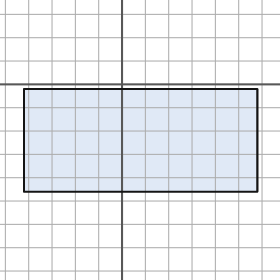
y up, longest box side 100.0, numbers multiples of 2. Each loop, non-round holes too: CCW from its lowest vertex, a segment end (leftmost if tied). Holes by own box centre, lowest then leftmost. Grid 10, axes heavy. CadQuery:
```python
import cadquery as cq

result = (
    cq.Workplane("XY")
    .moveTo(-42.0, -46.0)
    .lineTo(58.0, -46.0)
    .lineTo(58.0, -2.0)
    .lineTo(-42.0, -2.0)
    .close()
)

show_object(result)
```